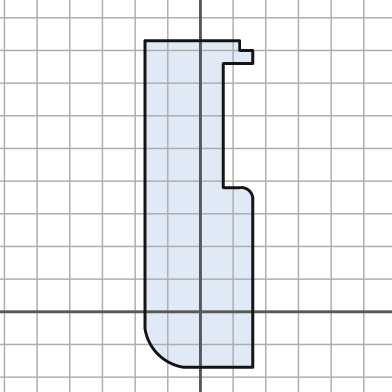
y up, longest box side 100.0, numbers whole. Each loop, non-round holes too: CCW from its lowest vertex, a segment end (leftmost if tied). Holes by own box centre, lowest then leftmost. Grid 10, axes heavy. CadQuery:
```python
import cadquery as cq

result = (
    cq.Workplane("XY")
    .moveTo(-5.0, -17.0)
    .lineTo(16.0, -17.0)
    .lineTo(16.0, 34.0)
    .threePointArc((15.0, 37.0), (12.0, 38.0))
    .lineTo(7.0, 38.0)
    .lineTo(7.0, 76.0)
    .lineTo(16.0, 76.0)
    .lineTo(16.0, 80.0)
    .lineTo(12.0, 80.0)
    .lineTo(12.0, 83.0)
    .lineTo(-17.0, 83.0)
    .lineTo(-17.0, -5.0)
    .threePointArc((-13.0, -13.0), (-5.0, -17.0))
    .close()
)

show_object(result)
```